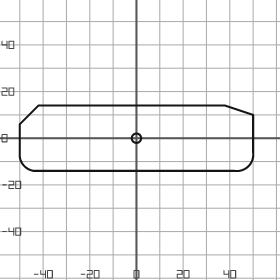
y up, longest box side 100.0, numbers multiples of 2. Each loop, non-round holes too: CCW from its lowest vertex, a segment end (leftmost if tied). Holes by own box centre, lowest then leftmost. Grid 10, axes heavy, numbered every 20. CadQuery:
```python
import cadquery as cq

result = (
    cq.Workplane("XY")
    .moveTo(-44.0, -14.0)
    .lineTo(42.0, -14.0)
    .threePointArc((48.0, -12.0), (50.0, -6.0))
    .lineTo(50.0, 10.0)
    .lineTo(38.0, 14.0)
    .lineTo(-42.0, 14.0)
    .lineTo(-50.0, 6.0)
    .lineTo(-50.0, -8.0)
    .threePointArc((-48.0, -12.0), (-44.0, -14.0))
    .close()
    .moveTo(0.0, 0.0)
    .circle(2.0)
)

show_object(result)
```